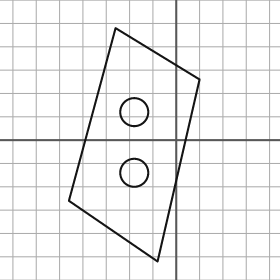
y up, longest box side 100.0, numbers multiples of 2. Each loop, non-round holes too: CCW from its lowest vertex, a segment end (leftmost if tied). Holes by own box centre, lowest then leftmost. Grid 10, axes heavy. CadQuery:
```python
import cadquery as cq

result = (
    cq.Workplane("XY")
    .moveTo(-8.0, -52.0)
    .lineTo(10.0, 26.0)
    .lineTo(-26.0, 48.0)
    .lineTo(-46.0, -26.0)
    .close()
    .moveTo(-18.0, -14.0)
    .circle(6.0)
    .moveTo(-18.0, 12.0)
    .circle(6.0)
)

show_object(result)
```